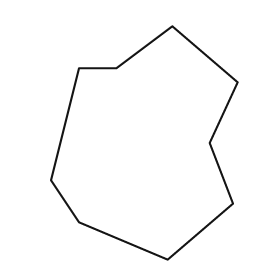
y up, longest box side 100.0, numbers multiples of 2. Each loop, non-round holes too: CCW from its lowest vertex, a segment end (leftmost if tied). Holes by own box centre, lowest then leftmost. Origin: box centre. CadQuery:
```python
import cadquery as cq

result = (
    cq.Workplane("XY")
    .moveTo(10.0, -50.0)
    .lineTo(38.0, -26.0)
    .lineTo(28.0, 0.0)
    .lineTo(40.0, 26.0)
    .lineTo(12.0, 50.0)
    .lineTo(-12.0, 32.0)
    .lineTo(-28.0, 32.0)
    .lineTo(-40.0, -16.0)
    .lineTo(-28.0, -34.0)
    .close()
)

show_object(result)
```